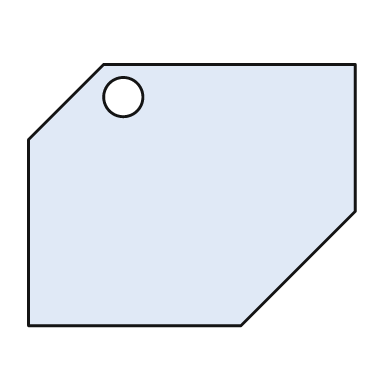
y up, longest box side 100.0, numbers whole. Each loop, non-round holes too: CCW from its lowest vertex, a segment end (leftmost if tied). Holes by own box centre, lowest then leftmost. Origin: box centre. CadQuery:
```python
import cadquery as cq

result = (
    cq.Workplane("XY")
    .moveTo(-50.0, -40.0)
    .lineTo(15.0, -40.0)
    .lineTo(50.0, -5.0)
    .lineTo(50.0, 40.0)
    .lineTo(-27.0, 40.0)
    .lineTo(-50.0, 17.0)
    .close()
    .moveTo(-21.0, 30.0)
    .circle(6.0)
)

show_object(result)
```